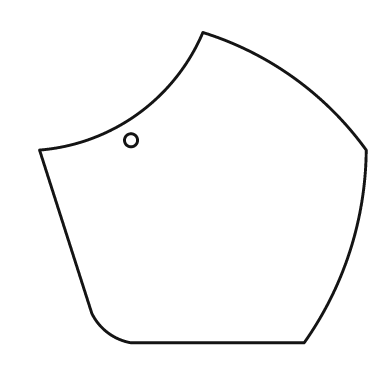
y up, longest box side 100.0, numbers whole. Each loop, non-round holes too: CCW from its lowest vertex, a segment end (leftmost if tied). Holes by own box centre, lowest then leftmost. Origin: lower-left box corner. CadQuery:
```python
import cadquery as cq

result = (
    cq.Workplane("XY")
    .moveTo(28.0, 0.0)
    .lineTo(81.0, 0.0)
    .threePointArc((95.0, 28.0), (100.0, 59.0))
    .threePointArc((78.0, 81.0), (50.0, 95.0))
    .threePointArc((30.0, 70.0), (0.0, 59.0))
    .lineTo(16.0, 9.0)
    .threePointArc((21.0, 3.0), (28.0, 0.0))
    .close()
    .moveTo(28.0, 62.0)
    .circle(2.0)
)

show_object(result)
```